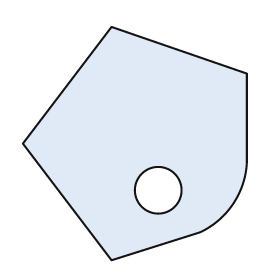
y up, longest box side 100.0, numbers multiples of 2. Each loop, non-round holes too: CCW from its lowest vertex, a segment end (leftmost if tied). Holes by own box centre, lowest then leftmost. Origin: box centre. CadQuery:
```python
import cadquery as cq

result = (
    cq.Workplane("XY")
    .moveTo(-10.0, -50.0)
    .lineTo(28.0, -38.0)
    .threePointArc((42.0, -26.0), (48.0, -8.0))
    .lineTo(48.0, 30.0)
    .lineTo(-10.0, 50.0)
    .lineTo(-48.0, 0.0)
    .close()
    .moveTo(10.0, -20.0)
    .circle(10.0)
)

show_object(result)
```